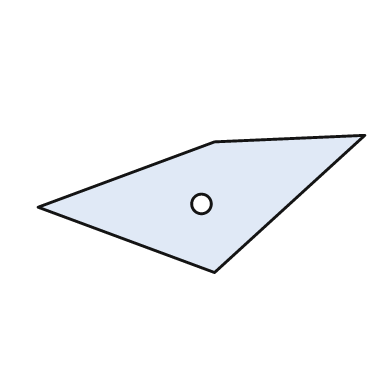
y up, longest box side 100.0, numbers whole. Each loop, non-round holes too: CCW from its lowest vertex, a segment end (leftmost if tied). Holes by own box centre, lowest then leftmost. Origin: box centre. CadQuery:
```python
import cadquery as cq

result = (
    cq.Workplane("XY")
    .moveTo(4.0, -21.0)
    .lineTo(50.0, 21.0)
    .lineTo(4.0, 19.0)
    .lineTo(-50.0, -1.0)
    .close()
    .moveTo(0.0, 0.0)
    .circle(3.0)
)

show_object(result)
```